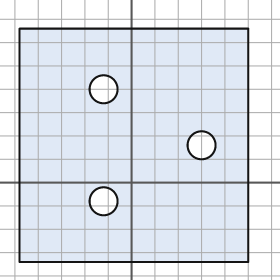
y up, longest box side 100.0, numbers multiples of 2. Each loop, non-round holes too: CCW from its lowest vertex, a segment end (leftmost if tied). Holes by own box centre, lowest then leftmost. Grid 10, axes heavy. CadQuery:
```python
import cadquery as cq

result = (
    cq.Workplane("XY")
    .moveTo(-48.0, -34.0)
    .lineTo(50.0, -34.0)
    .lineTo(50.0, 66.0)
    .lineTo(-48.0, 66.0)
    .close()
    .moveTo(-12.0, -8.0)
    .circle(6.0)
    .moveTo(30.0, 16.0)
    .circle(6.0)
    .moveTo(-12.0, 40.0)
    .circle(6.0)
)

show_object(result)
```